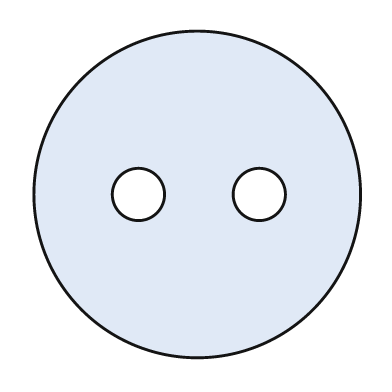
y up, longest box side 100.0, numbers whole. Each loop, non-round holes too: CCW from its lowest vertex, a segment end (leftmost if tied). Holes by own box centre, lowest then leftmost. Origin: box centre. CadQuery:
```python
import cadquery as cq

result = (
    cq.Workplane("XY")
    .moveTo(0.0, 0.0)
    .circle(50.0)
    .moveTo(-18.0, 0.0)
    .circle(8.0)
    .moveTo(19.0, 0.0)
    .circle(8.0)
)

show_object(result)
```